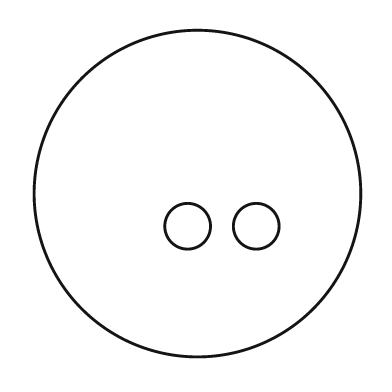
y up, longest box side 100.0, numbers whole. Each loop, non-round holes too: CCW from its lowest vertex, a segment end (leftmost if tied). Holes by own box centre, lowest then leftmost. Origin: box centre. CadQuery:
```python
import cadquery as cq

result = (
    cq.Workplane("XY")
    .moveTo(0.0, 0.0)
    .circle(50.0)
    .moveTo(-3.0, -10.0)
    .circle(7.0)
    .moveTo(18.0, -10.0)
    .circle(7.0)
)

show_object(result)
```